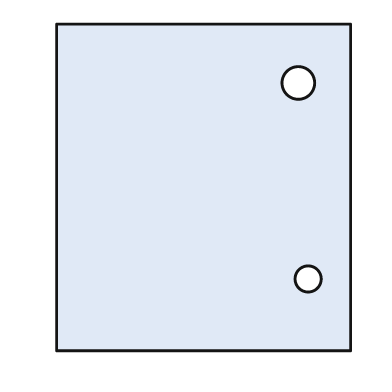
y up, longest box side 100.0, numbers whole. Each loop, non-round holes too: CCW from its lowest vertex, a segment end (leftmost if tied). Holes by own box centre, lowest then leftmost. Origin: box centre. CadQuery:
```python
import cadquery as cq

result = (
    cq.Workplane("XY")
    .moveTo(-45.0, -50.0)
    .lineTo(45.0, -50.0)
    .lineTo(45.0, 50.0)
    .lineTo(-45.0, 50.0)
    .close()
    .moveTo(32.0, -28.0)
    .circle(4.0)
    .moveTo(29.0, 32.0)
    .circle(5.0)
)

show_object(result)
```